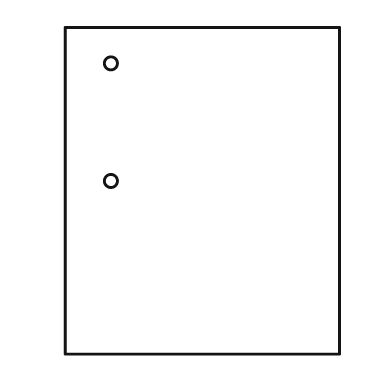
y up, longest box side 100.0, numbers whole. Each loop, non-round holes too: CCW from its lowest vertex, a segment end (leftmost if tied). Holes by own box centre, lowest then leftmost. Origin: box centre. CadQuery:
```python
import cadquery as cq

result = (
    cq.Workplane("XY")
    .moveTo(-42.0, -50.0)
    .lineTo(42.0, -50.0)
    .lineTo(42.0, 50.0)
    .lineTo(-42.0, 50.0)
    .close()
    .moveTo(-28.0, 3.0)
    .circle(2.0)
    .moveTo(-28.0, 39.0)
    .circle(2.0)
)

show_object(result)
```